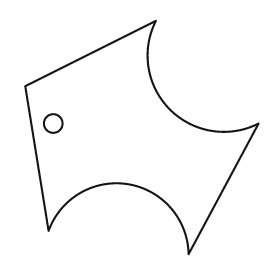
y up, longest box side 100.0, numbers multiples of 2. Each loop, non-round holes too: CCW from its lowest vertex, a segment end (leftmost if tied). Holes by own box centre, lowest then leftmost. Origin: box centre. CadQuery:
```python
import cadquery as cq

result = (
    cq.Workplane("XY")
    .moveTo(20.0, -50.0)
    .lineTo(50.0, 6.0)
    .threePointArc((12.0, 12.0), (6.0, 50.0))
    .lineTo(-50.0, 22.0)
    .lineTo(-40.0, -40.0)
    .threePointArc((-6.0, -20.0), (20.0, -50.0))
    .close()
    .moveTo(-38.0, 6.0)
    .circle(4.0)
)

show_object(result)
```